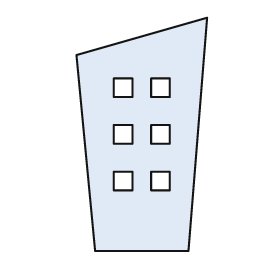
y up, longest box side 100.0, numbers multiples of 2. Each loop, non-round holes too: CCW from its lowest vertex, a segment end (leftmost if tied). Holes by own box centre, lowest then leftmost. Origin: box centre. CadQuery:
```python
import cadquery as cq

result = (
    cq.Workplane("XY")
    .moveTo(-20.0, -50.0)
    .lineTo(20.0, -50.0)
    .lineTo(28.0, 50.0)
    .lineTo(-28.0, 34.0)
    .close()
    .moveTo(-12.0, -24.0)
    .lineTo(-4.0, -24.0)
    .lineTo(-4.0, -16.0)
    .lineTo(-12.0, -16.0)
    .close()
    .moveTo(4.0, -24.0)
    .lineTo(12.0, -24.0)
    .lineTo(12.0, -16.0)
    .lineTo(4.0, -16.0)
    .close()
    .moveTo(-12.0, -4.0)
    .lineTo(-4.0, -4.0)
    .lineTo(-4.0, 4.0)
    .lineTo(-12.0, 4.0)
    .close()
    .moveTo(4.0, -4.0)
    .lineTo(12.0, -4.0)
    .lineTo(12.0, 4.0)
    .lineTo(4.0, 4.0)
    .close()
    .moveTo(-12.0, 16.0)
    .lineTo(-4.0, 16.0)
    .lineTo(-4.0, 24.0)
    .lineTo(-12.0, 24.0)
    .close()
    .moveTo(4.0, 16.0)
    .lineTo(12.0, 16.0)
    .lineTo(12.0, 24.0)
    .lineTo(4.0, 24.0)
    .close()
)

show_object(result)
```